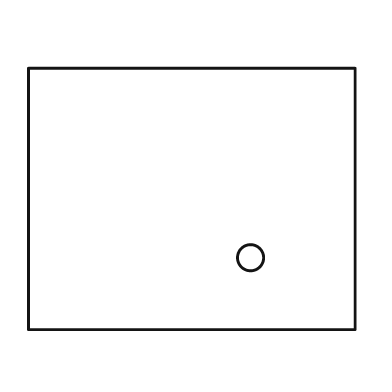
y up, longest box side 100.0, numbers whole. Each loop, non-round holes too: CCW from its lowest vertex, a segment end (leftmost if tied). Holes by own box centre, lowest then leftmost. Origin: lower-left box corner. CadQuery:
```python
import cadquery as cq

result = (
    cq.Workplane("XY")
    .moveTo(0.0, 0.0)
    .lineTo(100.0, 0.0)
    .lineTo(100.0, 80.0)
    .lineTo(0.0, 80.0)
    .close()
    .moveTo(68.0, 22.0)
    .circle(4.0)
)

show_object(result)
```